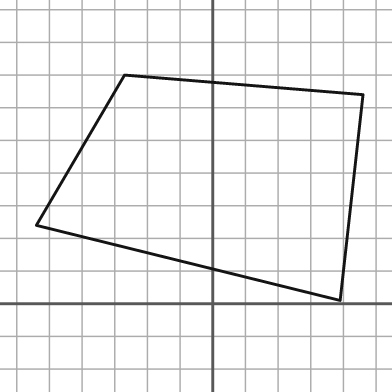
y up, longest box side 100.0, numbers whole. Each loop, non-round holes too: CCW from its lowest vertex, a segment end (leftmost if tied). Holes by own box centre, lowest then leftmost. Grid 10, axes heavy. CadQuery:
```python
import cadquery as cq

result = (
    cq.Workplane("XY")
    .moveTo(39.0, 1.0)
    .lineTo(46.0, 64.0)
    .lineTo(-27.0, 70.0)
    .lineTo(-54.0, 24.0)
    .close()
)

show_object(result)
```